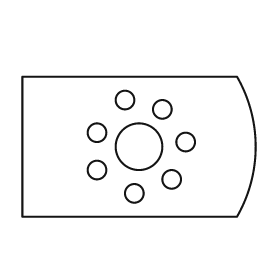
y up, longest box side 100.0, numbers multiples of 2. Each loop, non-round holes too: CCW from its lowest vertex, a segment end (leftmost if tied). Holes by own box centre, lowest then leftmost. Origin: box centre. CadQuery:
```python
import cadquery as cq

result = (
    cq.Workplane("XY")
    .moveTo(-50.0, -30.0)
    .lineTo(42.0, -30.0)
    .threePointArc((50.0, 0.0), (42.0, 30.0))
    .lineTo(-50.0, 30.0)
    .close()
    .moveTo(-2.0, -20.0)
    .circle(4.0)
    .moveTo(14.0, -14.0)
    .circle(4.0)
    .moveTo(-18.0, -10.0)
    .circle(4.0)
    .moveTo(0.0, 0.0)
    .circle(10.0)
    .moveTo(20.0, 2.0)
    .circle(4.0)
    .moveTo(-18.0, 6.0)
    .circle(4.0)
    .moveTo(10.0, 16.0)
    .circle(4.0)
    .moveTo(-6.0, 20.0)
    .circle(4.0)
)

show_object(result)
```